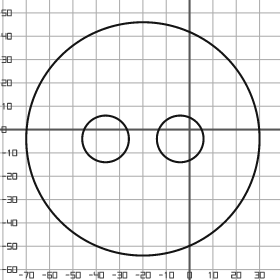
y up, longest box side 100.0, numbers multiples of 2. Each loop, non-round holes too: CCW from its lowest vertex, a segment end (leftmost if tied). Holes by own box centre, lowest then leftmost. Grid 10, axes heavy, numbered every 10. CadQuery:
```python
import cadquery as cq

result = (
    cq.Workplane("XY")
    .moveTo(-20.0, -4.0)
    .circle(50.0)
    .moveTo(-36.0, -4.0)
    .circle(10.0)
    .moveTo(-4.0, -4.0)
    .circle(10.0)
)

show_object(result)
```